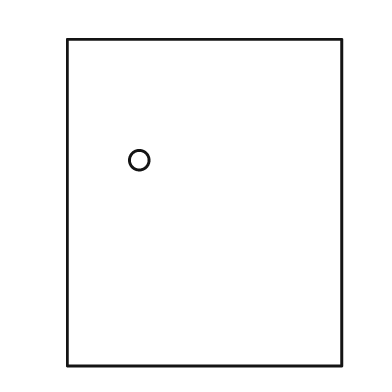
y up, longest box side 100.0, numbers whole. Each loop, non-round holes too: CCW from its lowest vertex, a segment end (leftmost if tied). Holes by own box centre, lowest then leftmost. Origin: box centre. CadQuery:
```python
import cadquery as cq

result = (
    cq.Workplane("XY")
    .moveTo(-42.0, -50.0)
    .lineTo(42.0, -50.0)
    .lineTo(42.0, 50.0)
    .lineTo(-42.0, 50.0)
    .close()
    .moveTo(-20.0, 13.0)
    .circle(3.0)
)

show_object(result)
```